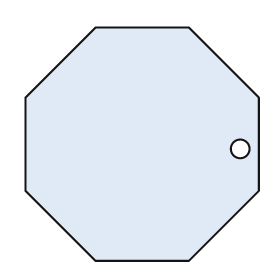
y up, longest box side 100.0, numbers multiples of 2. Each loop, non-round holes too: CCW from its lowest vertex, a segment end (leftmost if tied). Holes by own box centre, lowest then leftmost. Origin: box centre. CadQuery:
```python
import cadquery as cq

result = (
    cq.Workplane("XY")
    .moveTo(-20.0, -50.0)
    .lineTo(20.0, -50.0)
    .lineTo(50.0, -20.0)
    .lineTo(50.0, 20.0)
    .lineTo(20.0, 50.0)
    .lineTo(-20.0, 50.0)
    .lineTo(-50.0, 20.0)
    .lineTo(-50.0, -20.0)
    .close()
    .moveTo(42.0, -2.0)
    .circle(4.0)
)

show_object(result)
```